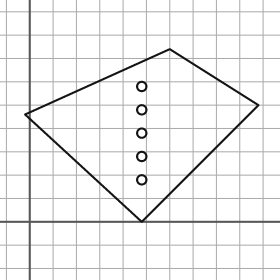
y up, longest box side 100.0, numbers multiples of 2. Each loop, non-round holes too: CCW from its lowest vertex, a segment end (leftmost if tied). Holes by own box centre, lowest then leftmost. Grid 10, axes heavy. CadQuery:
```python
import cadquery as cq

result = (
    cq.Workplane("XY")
    .moveTo(48.0, 0.0)
    .lineTo(98.0, 50.0)
    .lineTo(60.0, 74.0)
    .lineTo(-2.0, 46.0)
    .close()
    .moveTo(48.0, 18.0)
    .circle(2.0)
    .moveTo(48.0, 28.0)
    .circle(2.0)
    .moveTo(48.0, 38.0)
    .circle(2.0)
    .moveTo(48.0, 48.0)
    .circle(2.0)
    .moveTo(48.0, 58.0)
    .circle(2.0)
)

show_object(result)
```